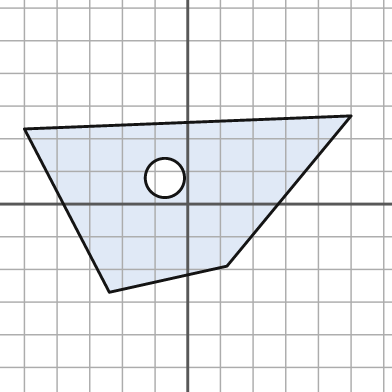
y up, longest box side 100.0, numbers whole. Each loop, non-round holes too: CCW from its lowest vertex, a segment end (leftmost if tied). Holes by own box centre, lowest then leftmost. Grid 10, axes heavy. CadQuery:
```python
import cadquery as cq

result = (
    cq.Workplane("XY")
    .moveTo(-24.0, -27.0)
    .lineTo(12.0, -19.0)
    .lineTo(50.0, 27.0)
    .lineTo(-50.0, 23.0)
    .close()
    .moveTo(-7.0, 8.0)
    .circle(6.0)
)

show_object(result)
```